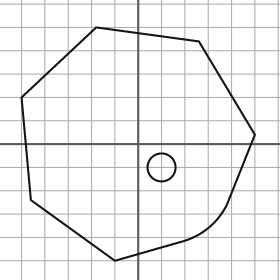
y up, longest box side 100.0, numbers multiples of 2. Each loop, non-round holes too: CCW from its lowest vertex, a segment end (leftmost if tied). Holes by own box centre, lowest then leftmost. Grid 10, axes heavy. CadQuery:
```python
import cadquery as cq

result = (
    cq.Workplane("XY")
    .moveTo(-10.0, -50.0)
    .lineTo(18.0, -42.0)
    .threePointArc((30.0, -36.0), (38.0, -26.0))
    .lineTo(50.0, 4.0)
    .lineTo(26.0, 44.0)
    .lineTo(-18.0, 50.0)
    .lineTo(-50.0, 20.0)
    .lineTo(-46.0, -24.0)
    .close()
    .moveTo(10.0, -10.0)
    .circle(6.0)
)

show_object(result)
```